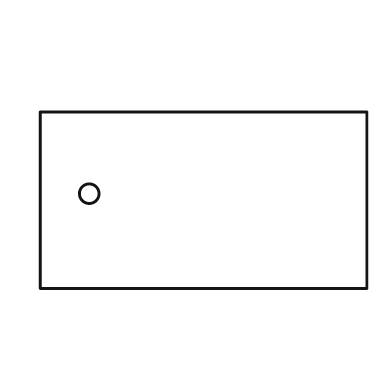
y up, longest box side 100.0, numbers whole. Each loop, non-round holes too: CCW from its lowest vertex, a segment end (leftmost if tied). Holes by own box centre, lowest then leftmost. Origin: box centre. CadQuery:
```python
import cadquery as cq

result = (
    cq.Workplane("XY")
    .moveTo(-50.0, -27.0)
    .lineTo(50.0, -27.0)
    .lineTo(50.0, 27.0)
    .lineTo(-50.0, 27.0)
    .close()
    .moveTo(-35.0, 2.0)
    .circle(3.0)
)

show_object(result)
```